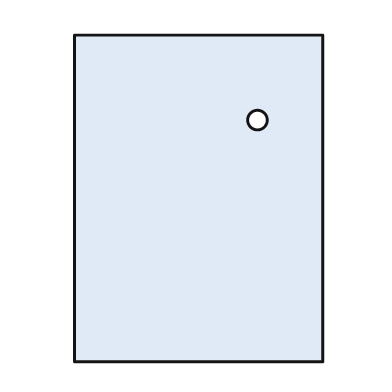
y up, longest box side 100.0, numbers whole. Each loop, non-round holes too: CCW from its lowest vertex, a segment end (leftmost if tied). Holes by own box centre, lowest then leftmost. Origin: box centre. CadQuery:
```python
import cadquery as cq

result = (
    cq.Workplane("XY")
    .moveTo(-38.0, -50.0)
    .lineTo(38.0, -50.0)
    .lineTo(38.0, 50.0)
    .lineTo(-38.0, 50.0)
    .close()
    .moveTo(18.0, 24.0)
    .circle(3.0)
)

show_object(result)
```